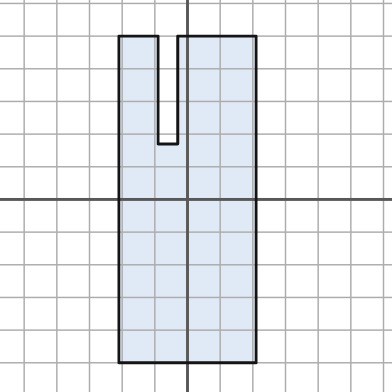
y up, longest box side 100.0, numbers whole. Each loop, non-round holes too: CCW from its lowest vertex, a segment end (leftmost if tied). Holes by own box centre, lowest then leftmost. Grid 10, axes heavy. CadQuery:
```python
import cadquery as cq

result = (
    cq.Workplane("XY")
    .moveTo(-21.0, -50.0)
    .lineTo(21.0, -50.0)
    .lineTo(21.0, 50.0)
    .lineTo(-3.0, 50.0)
    .lineTo(-3.0, 17.0)
    .lineTo(-9.0, 17.0)
    .lineTo(-9.0, 50.0)
    .lineTo(-21.0, 50.0)
    .close()
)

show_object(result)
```